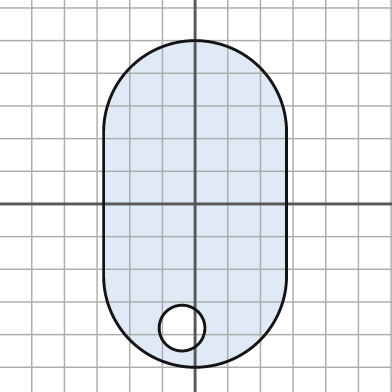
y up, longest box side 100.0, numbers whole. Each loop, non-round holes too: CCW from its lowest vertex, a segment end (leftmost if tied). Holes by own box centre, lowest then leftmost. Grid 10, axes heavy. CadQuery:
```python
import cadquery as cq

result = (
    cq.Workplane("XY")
    .moveTo(-28.0, -22.0)
    .threePointArc((0.0, -50.0), (28.0, -22.0))
    .lineTo(28.0, 22.0)
    .threePointArc((0.0, 50.0), (-28.0, 22.0))
    .close()
    .moveTo(-4.0, -38.0)
    .circle(7.0)
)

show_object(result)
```